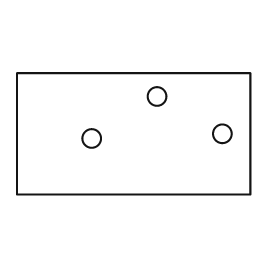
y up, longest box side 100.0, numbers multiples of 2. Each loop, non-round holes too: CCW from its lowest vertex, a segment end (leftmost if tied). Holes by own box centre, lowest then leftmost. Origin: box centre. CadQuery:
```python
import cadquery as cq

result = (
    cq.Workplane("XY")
    .moveTo(-50.0, -26.0)
    .lineTo(50.0, -26.0)
    .lineTo(50.0, 26.0)
    .lineTo(-50.0, 26.0)
    .close()
    .moveTo(-18.0, -2.0)
    .circle(4.0)
    .moveTo(38.0, 0.0)
    .circle(4.0)
    .moveTo(10.0, 16.0)
    .circle(4.0)
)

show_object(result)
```